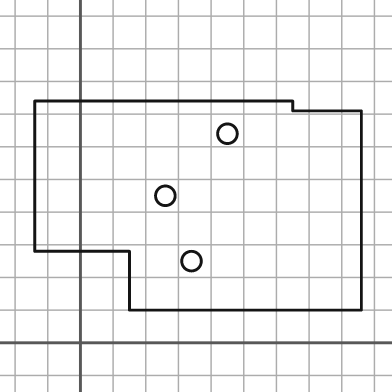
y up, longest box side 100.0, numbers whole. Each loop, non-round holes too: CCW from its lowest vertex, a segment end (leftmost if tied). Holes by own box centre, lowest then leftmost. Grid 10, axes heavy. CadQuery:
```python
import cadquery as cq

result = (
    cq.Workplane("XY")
    .moveTo(15.0, 10.0)
    .lineTo(86.0, 10.0)
    .lineTo(86.0, 71.0)
    .lineTo(65.0, 71.0)
    .lineTo(65.0, 74.0)
    .lineTo(-14.0, 74.0)
    .lineTo(-14.0, 28.0)
    .lineTo(15.0, 28.0)
    .close()
    .moveTo(34.0, 25.0)
    .circle(3.0)
    .moveTo(26.0, 45.0)
    .circle(3.0)
    .moveTo(45.0, 64.0)
    .circle(3.0)
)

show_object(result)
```